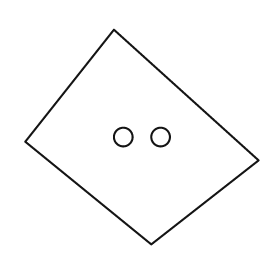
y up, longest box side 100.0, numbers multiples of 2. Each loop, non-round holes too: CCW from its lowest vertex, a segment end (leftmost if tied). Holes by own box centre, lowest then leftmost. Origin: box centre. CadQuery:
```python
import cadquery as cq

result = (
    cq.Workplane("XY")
    .moveTo(4.0, -46.0)
    .lineTo(50.0, -10.0)
    .lineTo(-12.0, 46.0)
    .lineTo(-50.0, -2.0)
    .close()
    .moveTo(-8.0, 0.0)
    .circle(4.0)
    .moveTo(8.0, 0.0)
    .circle(4.0)
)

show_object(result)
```